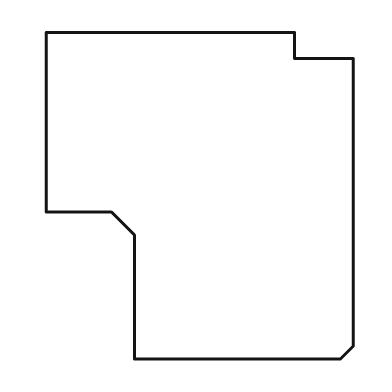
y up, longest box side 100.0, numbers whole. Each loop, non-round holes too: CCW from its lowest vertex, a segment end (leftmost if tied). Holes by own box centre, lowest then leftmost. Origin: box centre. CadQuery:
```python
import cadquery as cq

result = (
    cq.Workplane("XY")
    .moveTo(-20.0, -50.0)
    .lineTo(43.0, -50.0)
    .lineTo(47.0, -46.0)
    .lineTo(47.0, 42.0)
    .lineTo(29.0, 42.0)
    .lineTo(29.0, 50.0)
    .lineTo(-47.0, 50.0)
    .lineTo(-47.0, -5.0)
    .lineTo(-27.0, -5.0)
    .lineTo(-20.0, -12.0)
    .close()
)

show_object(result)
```